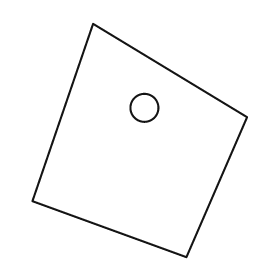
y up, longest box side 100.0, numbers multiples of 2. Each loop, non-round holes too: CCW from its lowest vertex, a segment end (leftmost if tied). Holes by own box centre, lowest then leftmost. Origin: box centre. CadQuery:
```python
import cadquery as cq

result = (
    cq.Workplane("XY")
    .moveTo(20.0, -50.0)
    .lineTo(46.0, 10.0)
    .lineTo(-20.0, 50.0)
    .lineTo(-46.0, -26.0)
    .close()
    .moveTo(2.0, 14.0)
    .circle(6.0)
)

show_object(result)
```